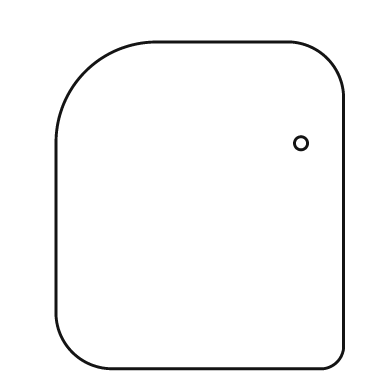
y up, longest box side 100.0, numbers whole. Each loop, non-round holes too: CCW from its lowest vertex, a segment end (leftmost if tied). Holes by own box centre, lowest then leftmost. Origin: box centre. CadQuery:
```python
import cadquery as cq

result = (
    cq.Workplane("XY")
    .moveTo(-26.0, -50.0)
    .lineTo(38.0, -50.0)
    .threePointArc((42.0, -48.0), (44.0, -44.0))
    .lineTo(44.0, 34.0)
    .threePointArc((39.0, 45.0), (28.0, 50.0))
    .lineTo(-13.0, 50.0)
    .threePointArc((-35.0, 41.0), (-44.0, 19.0))
    .lineTo(-44.0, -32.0)
    .threePointArc((-39.0, -45.0), (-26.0, -50.0))
    .close()
    .moveTo(31.0, 19.0)
    .circle(2.0)
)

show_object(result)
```